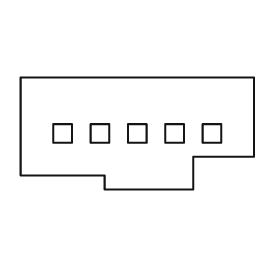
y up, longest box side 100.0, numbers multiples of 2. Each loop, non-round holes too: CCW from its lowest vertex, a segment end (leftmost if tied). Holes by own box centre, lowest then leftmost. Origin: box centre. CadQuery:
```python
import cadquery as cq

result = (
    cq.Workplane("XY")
    .moveTo(-14.0, -24.0)
    .lineTo(24.0, -24.0)
    .lineTo(24.0, -10.0)
    .lineTo(50.0, -10.0)
    .lineTo(50.0, 24.0)
    .lineTo(-50.0, 24.0)
    .lineTo(-50.0, -18.0)
    .lineTo(-14.0, -18.0)
    .close()
    .moveTo(-36.0, -4.0)
    .lineTo(-28.0, -4.0)
    .lineTo(-28.0, 4.0)
    .lineTo(-36.0, 4.0)
    .close()
    .moveTo(-20.0, -4.0)
    .lineTo(-12.0, -4.0)
    .lineTo(-12.0, 4.0)
    .lineTo(-20.0, 4.0)
    .close()
    .moveTo(-4.0, -4.0)
    .lineTo(4.0, -4.0)
    .lineTo(4.0, 4.0)
    .lineTo(-4.0, 4.0)
    .close()
    .moveTo(12.0, -4.0)
    .lineTo(20.0, -4.0)
    .lineTo(20.0, 4.0)
    .lineTo(12.0, 4.0)
    .close()
    .moveTo(28.0, -4.0)
    .lineTo(36.0, -4.0)
    .lineTo(36.0, 4.0)
    .lineTo(28.0, 4.0)
    .close()
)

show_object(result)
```